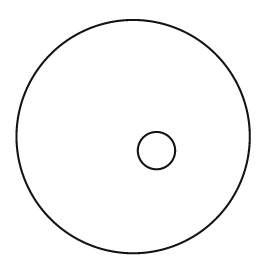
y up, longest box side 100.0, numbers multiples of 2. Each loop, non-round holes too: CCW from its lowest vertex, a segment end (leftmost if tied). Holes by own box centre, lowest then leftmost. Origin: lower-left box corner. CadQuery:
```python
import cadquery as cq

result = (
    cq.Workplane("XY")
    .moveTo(50.0, 50.0)
    .circle(50.0)
    .moveTo(60.0, 44.0)
    .circle(8.0)
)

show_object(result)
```